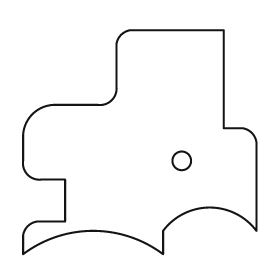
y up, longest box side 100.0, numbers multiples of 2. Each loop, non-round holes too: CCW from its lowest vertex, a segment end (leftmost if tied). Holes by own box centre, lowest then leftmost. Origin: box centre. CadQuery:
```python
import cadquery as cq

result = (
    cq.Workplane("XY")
    .moveTo(-50.0, -48.0)
    .threePointArc((-20.0, -38.0), (10.0, -48.0))
    .lineTo(10.0, -38.0)
    .threePointArc((30.0, -28.0), (50.0, -38.0))
    .lineTo(50.0, 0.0)
    .threePointArc((48.0, 4.0), (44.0, 6.0))
    .lineTo(36.0, 6.0)
    .lineTo(36.0, 48.0)
    .lineTo(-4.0, 48.0)
    .threePointArc((-8.0, 46.0), (-10.0, 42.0))
    .lineTo(-10.0, 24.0)
    .threePointArc((-12.0, 18.0), (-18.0, 16.0))
    .lineTo(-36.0, 16.0)
    .threePointArc((-46.0, 12.0), (-50.0, 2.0))
    .lineTo(-50.0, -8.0)
    .threePointArc((-48.0, -14.0), (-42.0, -16.0))
    .lineTo(-32.0, -16.0)
    .lineTo(-32.0, -34.0)
    .lineTo(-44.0, -34.0)
    .threePointArc((-48.0, -36.0), (-50.0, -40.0))
    .close()
    .moveTo(18.0, -8.0)
    .circle(4.0)
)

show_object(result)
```